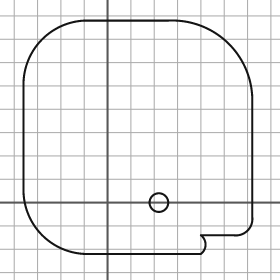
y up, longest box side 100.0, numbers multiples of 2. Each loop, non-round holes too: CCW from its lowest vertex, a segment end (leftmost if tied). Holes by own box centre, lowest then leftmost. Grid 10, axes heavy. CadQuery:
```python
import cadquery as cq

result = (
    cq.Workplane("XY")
    .moveTo(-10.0, -22.0)
    .lineTo(40.0, -22.0)
    .threePointArc((42.0, -18.0), (40.0, -14.0))
    .lineTo(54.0, -14.0)
    .threePointArc((60.0, -12.0), (62.0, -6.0))
    .lineTo(62.0, 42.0)
    .threePointArc((52.0, 68.0), (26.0, 78.0))
    .lineTo(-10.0, 78.0)
    .threePointArc((-28.0, 70.0), (-36.0, 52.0))
    .lineTo(-36.0, 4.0)
    .threePointArc((-28.0, -14.0), (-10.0, -22.0))
    .close()
    .moveTo(22.0, 0.0)
    .circle(4.0)
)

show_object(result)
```